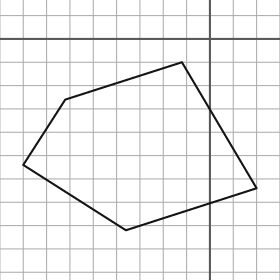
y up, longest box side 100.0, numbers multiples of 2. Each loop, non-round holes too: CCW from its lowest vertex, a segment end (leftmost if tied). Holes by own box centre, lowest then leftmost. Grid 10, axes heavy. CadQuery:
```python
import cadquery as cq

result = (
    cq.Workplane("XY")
    .moveTo(-36.0, -82.0)
    .lineTo(20.0, -64.0)
    .lineTo(-12.0, -10.0)
    .lineTo(-62.0, -26.0)
    .lineTo(-80.0, -54.0)
    .close()
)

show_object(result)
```